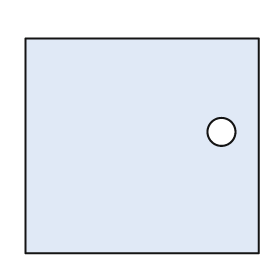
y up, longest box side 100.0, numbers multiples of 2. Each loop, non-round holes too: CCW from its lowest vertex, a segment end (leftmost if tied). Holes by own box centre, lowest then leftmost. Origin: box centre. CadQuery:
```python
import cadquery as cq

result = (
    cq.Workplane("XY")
    .moveTo(-50.0, -46.0)
    .lineTo(50.0, -46.0)
    .lineTo(50.0, 46.0)
    .lineTo(-50.0, 46.0)
    .close()
    .moveTo(34.0, 6.0)
    .circle(6.0)
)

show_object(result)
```